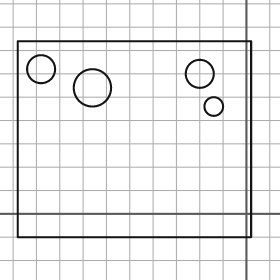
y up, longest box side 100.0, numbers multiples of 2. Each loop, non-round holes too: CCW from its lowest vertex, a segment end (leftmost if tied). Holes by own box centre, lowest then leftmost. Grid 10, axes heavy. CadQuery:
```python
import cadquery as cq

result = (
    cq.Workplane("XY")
    .moveTo(-98.0, -10.0)
    .lineTo(2.0, -10.0)
    .lineTo(2.0, 74.0)
    .lineTo(-98.0, 74.0)
    .close()
    .moveTo(-14.0, 46.0)
    .circle(4.0)
    .moveTo(-66.0, 54.0)
    .circle(8.0)
    .moveTo(-20.0, 60.0)
    .circle(6.0)
    .moveTo(-88.0, 62.0)
    .circle(6.0)
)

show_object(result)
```